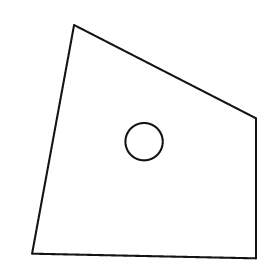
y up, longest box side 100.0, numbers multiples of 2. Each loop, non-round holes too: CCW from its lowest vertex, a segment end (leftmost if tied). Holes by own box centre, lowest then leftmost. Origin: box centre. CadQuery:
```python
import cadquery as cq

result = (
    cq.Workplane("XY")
    .moveTo(48.0, -50.0)
    .lineTo(48.0, 10.0)
    .lineTo(-30.0, 50.0)
    .lineTo(-48.0, -48.0)
    .close()
    .moveTo(0.0, 0.0)
    .circle(8.0)
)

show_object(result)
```